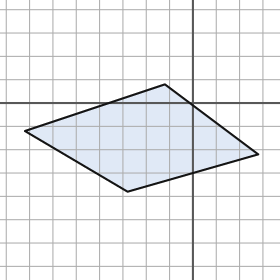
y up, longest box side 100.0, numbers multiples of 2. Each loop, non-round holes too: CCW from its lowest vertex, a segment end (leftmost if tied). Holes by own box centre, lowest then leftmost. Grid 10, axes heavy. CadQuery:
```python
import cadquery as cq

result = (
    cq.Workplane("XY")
    .moveTo(-28.0, -38.0)
    .lineTo(28.0, -22.0)
    .lineTo(-12.0, 8.0)
    .lineTo(-72.0, -12.0)
    .close()
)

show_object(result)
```